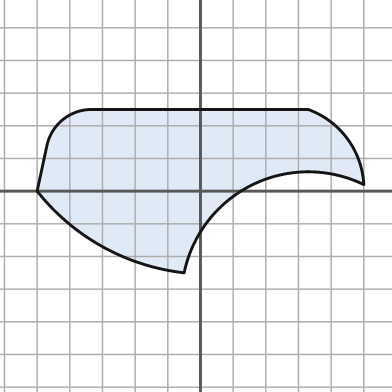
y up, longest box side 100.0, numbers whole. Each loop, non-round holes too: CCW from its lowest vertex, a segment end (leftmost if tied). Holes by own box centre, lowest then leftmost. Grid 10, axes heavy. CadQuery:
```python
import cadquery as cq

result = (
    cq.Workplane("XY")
    .moveTo(-5.0, -25.0)
    .threePointArc((16.0, 2.0), (50.0, 2.0))
    .threePointArc((45.0, 16.0), (33.0, 25.0))
    .lineTo(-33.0, 25.0)
    .threePointArc((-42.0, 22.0), (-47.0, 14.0))
    .lineTo(-50.0, 0.0)
    .threePointArc((-30.0, -17.0), (-5.0, -25.0))
    .close()
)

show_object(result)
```